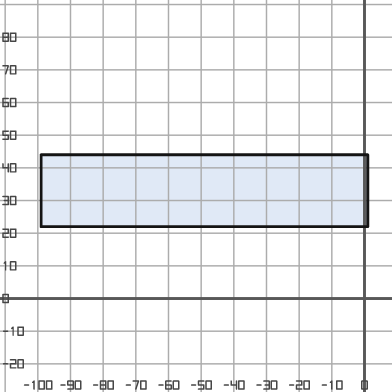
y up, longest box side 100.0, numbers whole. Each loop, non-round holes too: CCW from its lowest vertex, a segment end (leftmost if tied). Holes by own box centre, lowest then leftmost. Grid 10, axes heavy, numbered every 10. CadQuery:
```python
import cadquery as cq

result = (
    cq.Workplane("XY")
    .moveTo(-99.0, 22.0)
    .lineTo(1.0, 22.0)
    .lineTo(1.0, 44.0)
    .lineTo(-99.0, 44.0)
    .close()
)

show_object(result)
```